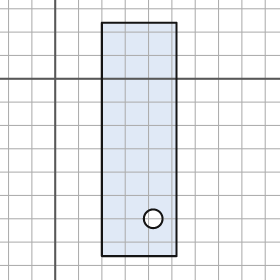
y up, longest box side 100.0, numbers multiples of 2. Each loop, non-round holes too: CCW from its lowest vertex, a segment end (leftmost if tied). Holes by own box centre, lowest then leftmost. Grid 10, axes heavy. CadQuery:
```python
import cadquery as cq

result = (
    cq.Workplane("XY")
    .moveTo(20.0, -76.0)
    .lineTo(52.0, -76.0)
    .lineTo(52.0, 24.0)
    .lineTo(20.0, 24.0)
    .close()
    .moveTo(42.0, -60.0)
    .circle(4.0)
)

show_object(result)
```